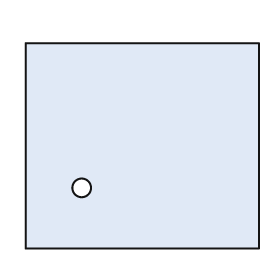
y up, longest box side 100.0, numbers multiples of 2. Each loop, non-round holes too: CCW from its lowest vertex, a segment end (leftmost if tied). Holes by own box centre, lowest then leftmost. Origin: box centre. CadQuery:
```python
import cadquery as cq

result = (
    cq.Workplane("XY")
    .moveTo(-50.0, -44.0)
    .lineTo(50.0, -44.0)
    .lineTo(50.0, 44.0)
    .lineTo(-50.0, 44.0)
    .close()
    .moveTo(-26.0, -18.0)
    .circle(4.0)
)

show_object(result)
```